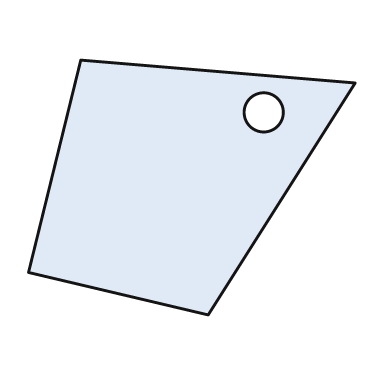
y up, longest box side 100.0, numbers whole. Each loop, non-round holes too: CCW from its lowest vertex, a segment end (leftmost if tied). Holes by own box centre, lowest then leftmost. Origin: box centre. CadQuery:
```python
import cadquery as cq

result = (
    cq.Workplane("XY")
    .moveTo(5.0, -39.0)
    .lineTo(50.0, 32.0)
    .lineTo(-34.0, 39.0)
    .lineTo(-50.0, -26.0)
    .close()
    .moveTo(22.0, 23.0)
    .circle(6.0)
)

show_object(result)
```